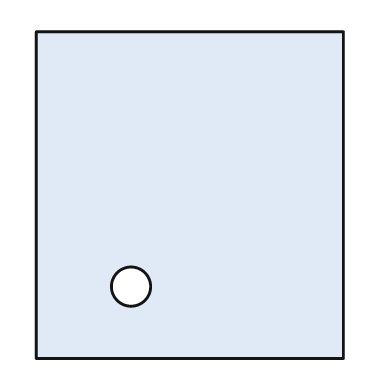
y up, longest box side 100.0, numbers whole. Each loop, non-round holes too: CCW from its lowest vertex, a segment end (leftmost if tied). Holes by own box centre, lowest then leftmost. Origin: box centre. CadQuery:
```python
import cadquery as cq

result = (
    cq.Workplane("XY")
    .moveTo(-47.0, -50.0)
    .lineTo(47.0, -50.0)
    .lineTo(47.0, 50.0)
    .lineTo(-47.0, 50.0)
    .close()
    .moveTo(-18.0, -28.0)
    .circle(6.0)
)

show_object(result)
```